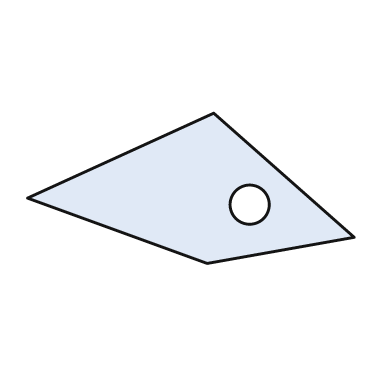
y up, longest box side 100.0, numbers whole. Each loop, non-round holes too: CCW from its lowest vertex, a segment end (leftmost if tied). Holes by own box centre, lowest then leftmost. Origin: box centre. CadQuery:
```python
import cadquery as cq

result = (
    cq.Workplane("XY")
    .moveTo(5.0, -23.0)
    .lineTo(50.0, -15.0)
    .lineTo(7.0, 23.0)
    .lineTo(-50.0, -3.0)
    .close()
    .moveTo(18.0, -5.0)
    .circle(6.0)
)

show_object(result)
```